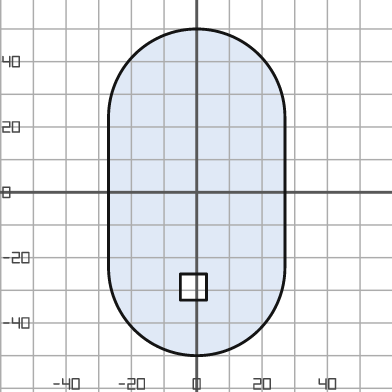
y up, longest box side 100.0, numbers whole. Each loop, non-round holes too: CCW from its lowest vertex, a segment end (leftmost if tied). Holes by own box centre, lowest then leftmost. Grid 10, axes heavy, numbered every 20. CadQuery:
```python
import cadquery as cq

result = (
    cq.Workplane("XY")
    .moveTo(-27.0, -23.0)
    .threePointArc((0.0, -50.0), (27.0, -23.0))
    .lineTo(27.0, 23.0)
    .threePointArc((0.0, 50.0), (-27.0, 23.0))
    .close()
    .moveTo(-5.0, -33.0)
    .lineTo(3.0, -33.0)
    .lineTo(3.0, -25.0)
    .lineTo(-5.0, -25.0)
    .close()
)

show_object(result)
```